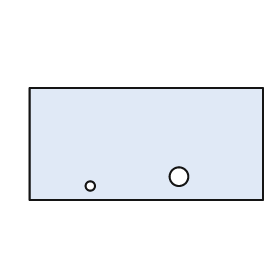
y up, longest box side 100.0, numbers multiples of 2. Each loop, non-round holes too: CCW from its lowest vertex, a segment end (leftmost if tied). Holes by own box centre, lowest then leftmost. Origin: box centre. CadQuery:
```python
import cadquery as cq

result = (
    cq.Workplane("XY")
    .moveTo(-50.0, -24.0)
    .lineTo(50.0, -24.0)
    .lineTo(50.0, 24.0)
    .lineTo(-50.0, 24.0)
    .close()
    .moveTo(-24.0, -18.0)
    .circle(2.0)
    .moveTo(14.0, -14.0)
    .circle(4.0)
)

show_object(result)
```